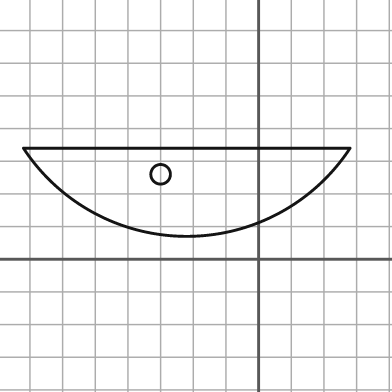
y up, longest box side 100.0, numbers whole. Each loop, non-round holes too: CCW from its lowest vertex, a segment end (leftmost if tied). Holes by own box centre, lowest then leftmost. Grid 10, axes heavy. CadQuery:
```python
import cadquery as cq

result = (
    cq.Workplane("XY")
    .moveTo(-72.0, 34.0)
    .threePointArc((-22.0, 7.0), (28.0, 34.0))
    .close()
    .moveTo(-30.0, 26.0)
    .circle(3.0)
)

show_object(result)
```